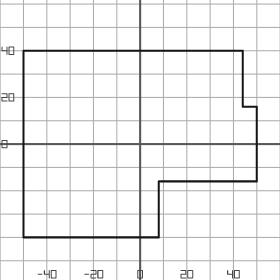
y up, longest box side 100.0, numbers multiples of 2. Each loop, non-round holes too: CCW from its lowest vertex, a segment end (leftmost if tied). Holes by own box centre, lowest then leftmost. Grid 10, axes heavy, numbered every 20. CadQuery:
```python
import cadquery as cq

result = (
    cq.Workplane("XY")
    .moveTo(-50.0, -40.0)
    .lineTo(8.0, -40.0)
    .lineTo(8.0, -16.0)
    .lineTo(50.0, -16.0)
    .lineTo(50.0, 16.0)
    .lineTo(44.0, 16.0)
    .lineTo(44.0, 40.0)
    .lineTo(-50.0, 40.0)
    .close()
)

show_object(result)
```